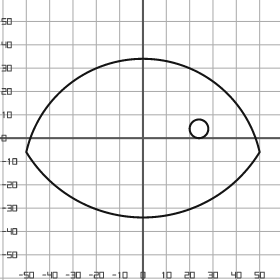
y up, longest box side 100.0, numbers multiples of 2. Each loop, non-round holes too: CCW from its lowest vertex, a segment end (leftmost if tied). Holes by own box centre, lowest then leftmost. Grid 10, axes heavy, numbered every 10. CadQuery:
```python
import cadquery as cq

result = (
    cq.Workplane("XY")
    .moveTo(-50.0, -6.0)
    .threePointArc((0.0, -34.0), (50.0, -6.0))
    .threePointArc((0.0, 34.0), (-50.0, -6.0))
    .close()
    .moveTo(24.0, 4.0)
    .circle(4.0)
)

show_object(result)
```